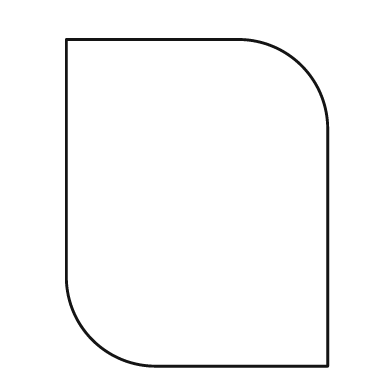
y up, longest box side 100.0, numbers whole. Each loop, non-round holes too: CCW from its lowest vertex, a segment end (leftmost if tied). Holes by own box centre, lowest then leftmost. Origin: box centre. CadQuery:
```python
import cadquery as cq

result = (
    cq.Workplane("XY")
    .moveTo(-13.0, -50.0)
    .lineTo(40.0, -50.0)
    .lineTo(40.0, 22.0)
    .threePointArc((32.0, 42.0), (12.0, 50.0))
    .lineTo(-40.0, 50.0)
    .lineTo(-40.0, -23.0)
    .threePointArc((-32.0, -42.0), (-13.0, -50.0))
    .close()
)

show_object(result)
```